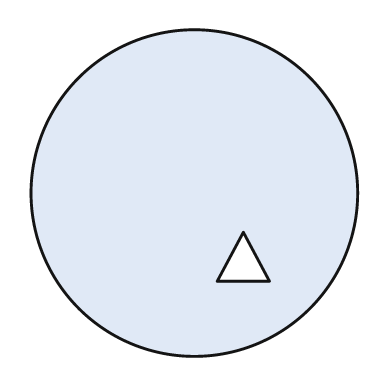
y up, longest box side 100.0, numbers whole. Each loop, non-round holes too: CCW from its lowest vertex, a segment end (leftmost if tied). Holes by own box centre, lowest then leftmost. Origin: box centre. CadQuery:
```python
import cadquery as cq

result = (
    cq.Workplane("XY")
    .moveTo(0.0, 0.0)
    .circle(50.0)
    .moveTo(7.0, -27.0)
    .lineTo(23.0, -27.0)
    .lineTo(15.0, -12.0)
    .close()
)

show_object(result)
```